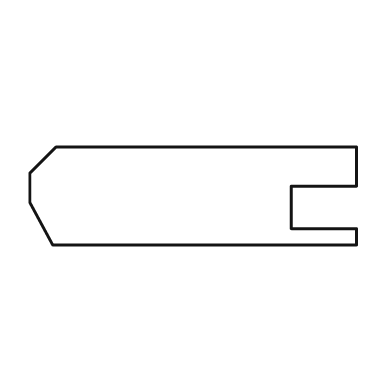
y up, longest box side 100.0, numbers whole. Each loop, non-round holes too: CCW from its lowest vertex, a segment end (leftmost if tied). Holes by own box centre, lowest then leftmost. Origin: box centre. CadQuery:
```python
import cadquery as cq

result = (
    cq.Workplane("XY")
    .moveTo(-43.0, -15.0)
    .lineTo(50.0, -15.0)
    .lineTo(50.0, -10.0)
    .lineTo(30.0, -10.0)
    .lineTo(30.0, 3.0)
    .lineTo(50.0, 3.0)
    .lineTo(50.0, 15.0)
    .lineTo(-42.0, 15.0)
    .lineTo(-50.0, 7.0)
    .lineTo(-50.0, -2.0)
    .close()
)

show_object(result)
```